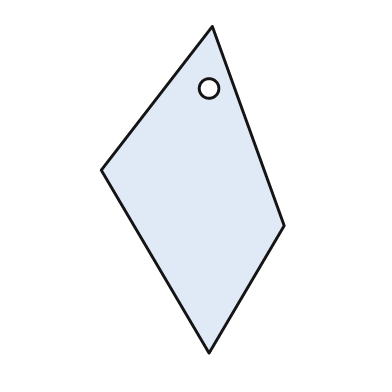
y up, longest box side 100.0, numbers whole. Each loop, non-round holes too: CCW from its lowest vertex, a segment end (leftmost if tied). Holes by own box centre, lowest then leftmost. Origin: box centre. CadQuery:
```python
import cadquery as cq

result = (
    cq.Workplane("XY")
    .moveTo(5.0, -50.0)
    .lineTo(28.0, -11.0)
    .lineTo(6.0, 50.0)
    .lineTo(-28.0, 6.0)
    .close()
    .moveTo(5.0, 31.0)
    .circle(3.0)
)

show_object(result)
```